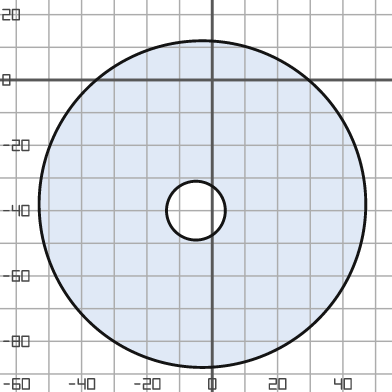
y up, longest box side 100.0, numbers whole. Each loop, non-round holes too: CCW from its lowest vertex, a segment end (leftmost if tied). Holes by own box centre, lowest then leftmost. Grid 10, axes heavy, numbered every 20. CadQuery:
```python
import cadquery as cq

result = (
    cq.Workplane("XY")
    .moveTo(-3.0, -38.0)
    .circle(50.0)
    .moveTo(-5.0, -40.0)
    .circle(9.0)
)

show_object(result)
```